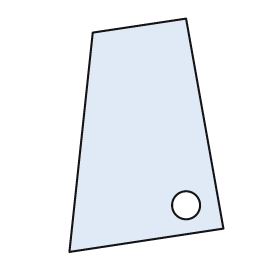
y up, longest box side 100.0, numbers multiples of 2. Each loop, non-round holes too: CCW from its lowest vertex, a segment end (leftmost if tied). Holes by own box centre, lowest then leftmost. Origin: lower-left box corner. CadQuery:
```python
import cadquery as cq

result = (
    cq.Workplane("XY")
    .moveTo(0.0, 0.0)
    .lineTo(66.0, 10.0)
    .lineTo(50.0, 100.0)
    .lineTo(10.0, 94.0)
    .close()
    .moveTo(50.0, 20.0)
    .circle(6.0)
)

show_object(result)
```